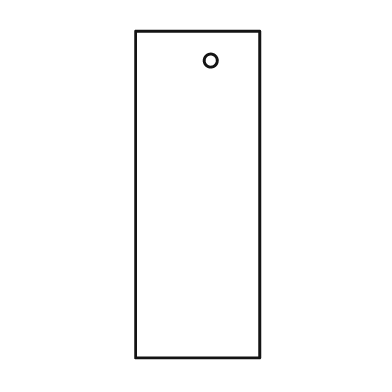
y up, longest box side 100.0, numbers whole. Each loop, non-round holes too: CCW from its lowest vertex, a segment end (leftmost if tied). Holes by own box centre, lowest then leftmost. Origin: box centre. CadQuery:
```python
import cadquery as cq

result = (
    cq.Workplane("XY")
    .moveTo(-19.0, -50.0)
    .lineTo(19.0, -50.0)
    .lineTo(19.0, 50.0)
    .lineTo(-19.0, 50.0)
    .close()
    .moveTo(4.0, 41.0)
    .circle(2.0)
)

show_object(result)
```